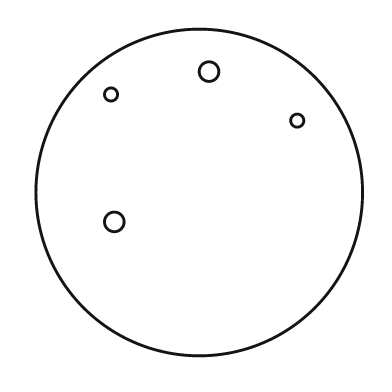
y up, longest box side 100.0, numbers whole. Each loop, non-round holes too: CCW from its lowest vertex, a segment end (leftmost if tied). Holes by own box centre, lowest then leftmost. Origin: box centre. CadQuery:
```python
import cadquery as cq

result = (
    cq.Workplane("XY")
    .moveTo(0.0, 0.0)
    .circle(50.0)
    .moveTo(-26.0, -9.0)
    .circle(3.0)
    .moveTo(30.0, 22.0)
    .circle(2.0)
    .moveTo(-27.0, 30.0)
    .circle(2.0)
    .moveTo(3.0, 37.0)
    .circle(3.0)
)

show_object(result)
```